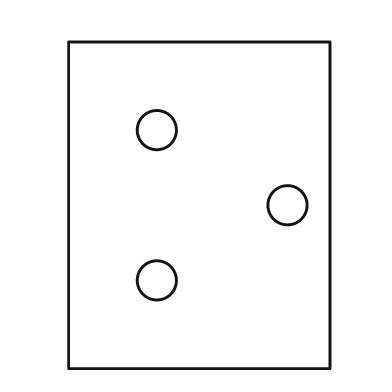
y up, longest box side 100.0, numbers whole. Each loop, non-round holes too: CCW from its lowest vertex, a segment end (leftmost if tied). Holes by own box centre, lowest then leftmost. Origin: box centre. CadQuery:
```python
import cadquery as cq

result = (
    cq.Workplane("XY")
    .moveTo(-40.0, -50.0)
    .lineTo(40.0, -50.0)
    .lineTo(40.0, 50.0)
    .lineTo(-40.0, 50.0)
    .close()
    .moveTo(-13.0, -23.0)
    .circle(6.0)
    .moveTo(27.0, 0.0)
    .circle(6.0)
    .moveTo(-13.0, 23.0)
    .circle(6.0)
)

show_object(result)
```